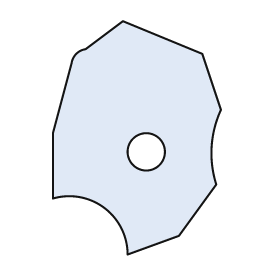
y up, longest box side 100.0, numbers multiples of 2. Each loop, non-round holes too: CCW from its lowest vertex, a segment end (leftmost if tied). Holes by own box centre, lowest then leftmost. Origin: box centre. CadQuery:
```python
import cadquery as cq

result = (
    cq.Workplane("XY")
    .moveTo(-4.0, -50.0)
    .lineTo(18.0, -42.0)
    .lineTo(34.0, -20.0)
    .threePointArc((32.0, -4.0), (36.0, 12.0))
    .lineTo(28.0, 36.0)
    .lineTo(-6.0, 50.0)
    .lineTo(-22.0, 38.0)
    .threePointArc((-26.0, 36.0), (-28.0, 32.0))
    .lineTo(-36.0, 2.0)
    .lineTo(-36.0, -26.0)
    .threePointArc((-14.0, -30.0), (-4.0, -50.0))
    .close()
    .moveTo(4.0, -6.0)
    .circle(8.0)
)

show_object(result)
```